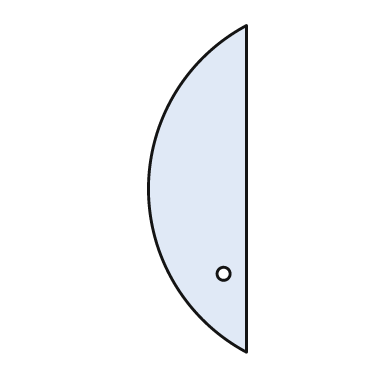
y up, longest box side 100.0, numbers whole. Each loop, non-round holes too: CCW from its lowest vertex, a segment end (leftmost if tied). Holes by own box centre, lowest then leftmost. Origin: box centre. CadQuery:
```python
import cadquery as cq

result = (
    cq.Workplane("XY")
    .moveTo(15.0, -50.0)
    .lineTo(15.0, 50.0)
    .threePointArc((-15.0, 0.0), (15.0, -50.0))
    .close()
    .moveTo(8.0, -26.0)
    .circle(2.0)
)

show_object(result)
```